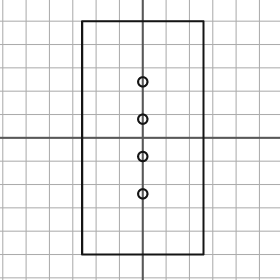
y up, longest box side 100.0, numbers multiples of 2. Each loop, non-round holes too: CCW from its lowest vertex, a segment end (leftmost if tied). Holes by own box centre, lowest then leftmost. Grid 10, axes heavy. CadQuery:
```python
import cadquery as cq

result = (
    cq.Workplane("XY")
    .moveTo(-26.0, -50.0)
    .lineTo(26.0, -50.0)
    .lineTo(26.0, 50.0)
    .lineTo(-26.0, 50.0)
    .close()
    .moveTo(0.0, -24.0)
    .circle(2.0)
    .moveTo(0.0, -8.0)
    .circle(2.0)
    .moveTo(0.0, 8.0)
    .circle(2.0)
    .moveTo(0.0, 24.0)
    .circle(2.0)
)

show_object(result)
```